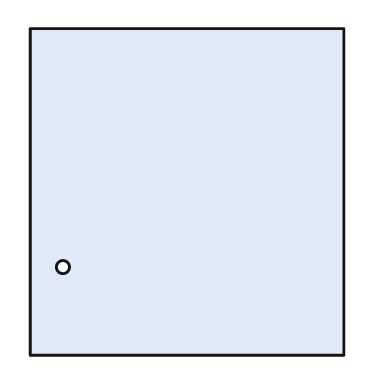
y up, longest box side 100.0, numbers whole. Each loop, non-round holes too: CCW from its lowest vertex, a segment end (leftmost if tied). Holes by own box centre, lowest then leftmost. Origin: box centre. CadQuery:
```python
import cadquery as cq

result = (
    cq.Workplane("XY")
    .moveTo(-48.0, -50.0)
    .lineTo(48.0, -50.0)
    .lineTo(48.0, 50.0)
    .lineTo(-48.0, 50.0)
    .close()
    .moveTo(-38.0, -23.0)
    .circle(2.0)
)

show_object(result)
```